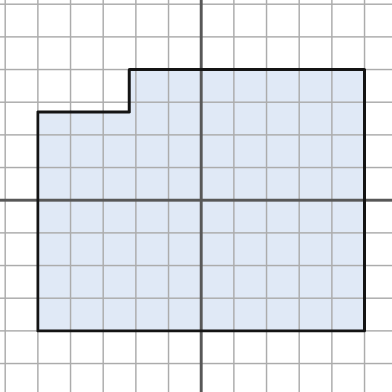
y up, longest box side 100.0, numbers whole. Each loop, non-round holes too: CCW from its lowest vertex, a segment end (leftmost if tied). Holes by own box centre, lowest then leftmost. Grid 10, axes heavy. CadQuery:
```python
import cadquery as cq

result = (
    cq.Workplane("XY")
    .moveTo(-50.0, -40.0)
    .lineTo(50.0, -40.0)
    .lineTo(50.0, 40.0)
    .lineTo(-22.0, 40.0)
    .lineTo(-22.0, 27.0)
    .lineTo(-50.0, 27.0)
    .close()
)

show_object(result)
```